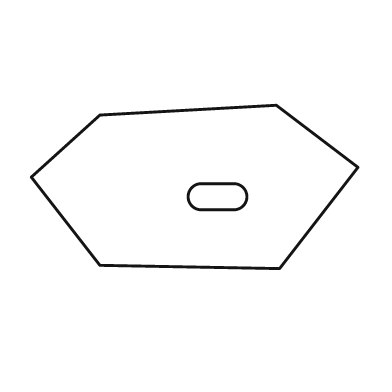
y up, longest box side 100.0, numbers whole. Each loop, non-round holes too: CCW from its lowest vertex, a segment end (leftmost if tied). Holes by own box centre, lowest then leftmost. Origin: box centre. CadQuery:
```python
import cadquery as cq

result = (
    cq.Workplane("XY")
    .moveTo(26.0, -25.0)
    .lineTo(50.0, 6.0)
    .lineTo(25.0, 25.0)
    .lineTo(-29.0, 22.0)
    .lineTo(-50.0, 3.0)
    .lineTo(-29.0, -24.0)
    .close()
    .moveTo(2.0, -7.0)
    .lineTo(12.0, -7.0)
    .threePointArc((16.0, -3.0), (12.0, 1.0))
    .lineTo(2.0, 1.0)
    .threePointArc((-2.0, -3.0), (2.0, -7.0))
    .close()
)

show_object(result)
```